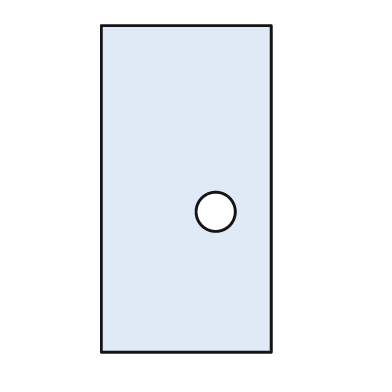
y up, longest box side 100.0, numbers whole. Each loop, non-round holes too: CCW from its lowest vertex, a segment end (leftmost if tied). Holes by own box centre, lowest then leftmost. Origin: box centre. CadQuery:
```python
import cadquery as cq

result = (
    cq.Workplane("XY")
    .moveTo(-26.0, -50.0)
    .lineTo(26.0, -50.0)
    .lineTo(26.0, 50.0)
    .lineTo(-26.0, 50.0)
    .close()
    .moveTo(9.0, -7.0)
    .circle(6.0)
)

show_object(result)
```